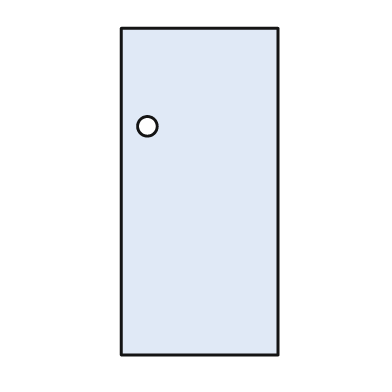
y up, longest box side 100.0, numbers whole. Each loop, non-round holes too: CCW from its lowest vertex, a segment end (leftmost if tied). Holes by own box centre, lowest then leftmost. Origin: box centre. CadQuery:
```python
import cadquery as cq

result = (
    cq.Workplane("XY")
    .moveTo(-24.0, -50.0)
    .lineTo(24.0, -50.0)
    .lineTo(24.0, 50.0)
    .lineTo(-24.0, 50.0)
    .close()
    .moveTo(-16.0, 20.0)
    .circle(3.0)
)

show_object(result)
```